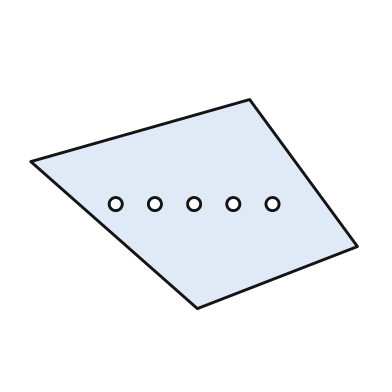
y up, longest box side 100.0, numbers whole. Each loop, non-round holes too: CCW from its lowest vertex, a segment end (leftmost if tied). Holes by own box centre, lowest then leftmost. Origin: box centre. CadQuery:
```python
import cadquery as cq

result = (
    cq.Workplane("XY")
    .moveTo(1.0, -32.0)
    .lineTo(50.0, -13.0)
    .lineTo(17.0, 32.0)
    .lineTo(-50.0, 13.0)
    .close()
    .moveTo(-24.0, 0.0)
    .circle(2.0)
    .moveTo(-12.0, 0.0)
    .circle(2.0)
    .moveTo(0.0, 0.0)
    .circle(2.0)
    .moveTo(12.0, 0.0)
    .circle(2.0)
    .moveTo(24.0, 0.0)
    .circle(2.0)
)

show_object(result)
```